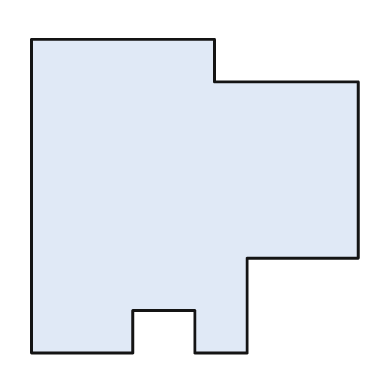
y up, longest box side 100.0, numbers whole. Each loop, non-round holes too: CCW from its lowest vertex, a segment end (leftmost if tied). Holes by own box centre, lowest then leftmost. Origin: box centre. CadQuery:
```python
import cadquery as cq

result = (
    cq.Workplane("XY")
    .moveTo(-50.0, -48.0)
    .lineTo(-19.0, -48.0)
    .lineTo(-19.0, -35.0)
    .lineTo(0.0, -35.0)
    .lineTo(0.0, -48.0)
    .lineTo(16.0, -48.0)
    .lineTo(16.0, -19.0)
    .lineTo(50.0, -19.0)
    .lineTo(50.0, 35.0)
    .lineTo(6.0, 35.0)
    .lineTo(6.0, 48.0)
    .lineTo(-50.0, 48.0)
    .close()
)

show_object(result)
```